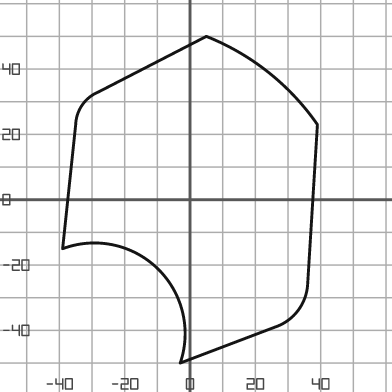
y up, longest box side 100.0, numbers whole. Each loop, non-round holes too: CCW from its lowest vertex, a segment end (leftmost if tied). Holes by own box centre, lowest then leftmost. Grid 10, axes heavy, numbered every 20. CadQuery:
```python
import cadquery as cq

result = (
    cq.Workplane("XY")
    .moveTo(-3.0, -50.0)
    .lineTo(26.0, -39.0)
    .threePointArc((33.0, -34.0), (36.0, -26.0))
    .lineTo(39.0, 23.0)
    .threePointArc((24.0, 39.0), (5.0, 50.0))
    .lineTo(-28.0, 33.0)
    .threePointArc((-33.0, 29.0), (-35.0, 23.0))
    .lineTo(-39.0, -15.0)
    .threePointArc((-10.0, -21.0), (-3.0, -50.0))
    .close()
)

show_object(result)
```